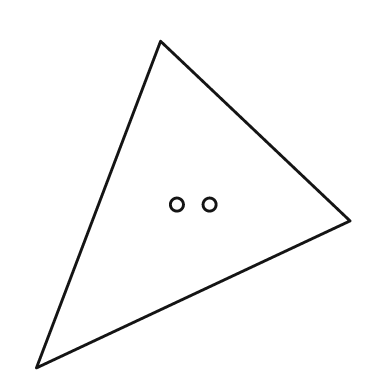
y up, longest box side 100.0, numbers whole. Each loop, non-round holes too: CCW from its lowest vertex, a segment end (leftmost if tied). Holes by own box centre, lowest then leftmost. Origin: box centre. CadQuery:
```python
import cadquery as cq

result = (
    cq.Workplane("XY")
    .moveTo(-48.0, -50.0)
    .lineTo(48.0, -5.0)
    .lineTo(-10.0, 50.0)
    .close()
    .moveTo(-5.0, 0.0)
    .circle(2.0)
    .moveTo(5.0, 0.0)
    .circle(2.0)
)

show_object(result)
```